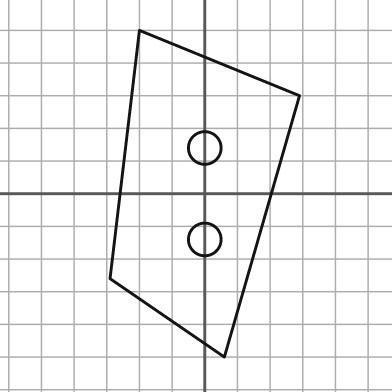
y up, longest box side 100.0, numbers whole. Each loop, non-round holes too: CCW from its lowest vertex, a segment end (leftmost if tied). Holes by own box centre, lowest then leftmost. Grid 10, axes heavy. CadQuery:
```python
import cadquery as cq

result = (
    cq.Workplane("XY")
    .moveTo(6.0, -50.0)
    .lineTo(29.0, 30.0)
    .lineTo(-20.0, 50.0)
    .lineTo(-29.0, -26.0)
    .close()
    .moveTo(0.0, -14.0)
    .circle(5.0)
    .moveTo(0.0, 14.0)
    .circle(5.0)
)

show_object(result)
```